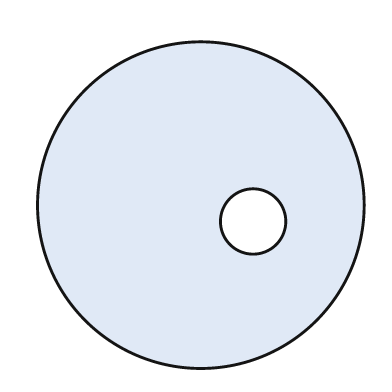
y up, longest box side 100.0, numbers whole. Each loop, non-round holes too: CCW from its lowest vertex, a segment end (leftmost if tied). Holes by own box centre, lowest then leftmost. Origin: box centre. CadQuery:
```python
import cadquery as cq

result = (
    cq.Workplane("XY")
    .moveTo(0.0, 0.0)
    .circle(50.0)
    .moveTo(16.0, -5.0)
    .circle(10.0)
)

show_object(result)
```